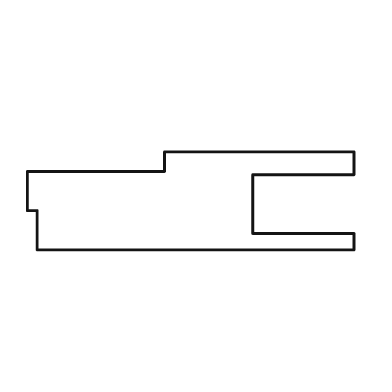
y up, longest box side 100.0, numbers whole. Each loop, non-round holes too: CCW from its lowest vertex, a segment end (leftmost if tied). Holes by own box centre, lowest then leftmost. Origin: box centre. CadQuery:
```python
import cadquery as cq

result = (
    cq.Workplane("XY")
    .moveTo(-47.0, -15.0)
    .lineTo(50.0, -15.0)
    .lineTo(50.0, -10.0)
    .lineTo(19.0, -10.0)
    .lineTo(19.0, 8.0)
    .lineTo(50.0, 8.0)
    .lineTo(50.0, 15.0)
    .lineTo(-8.0, 15.0)
    .lineTo(-8.0, 9.0)
    .lineTo(-50.0, 9.0)
    .lineTo(-50.0, -3.0)
    .lineTo(-47.0, -3.0)
    .close()
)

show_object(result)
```